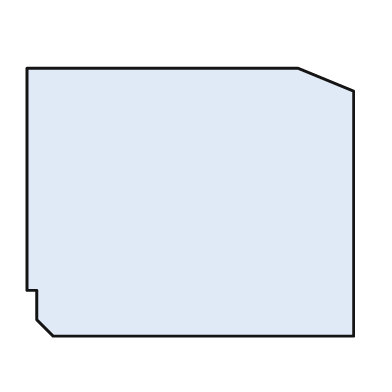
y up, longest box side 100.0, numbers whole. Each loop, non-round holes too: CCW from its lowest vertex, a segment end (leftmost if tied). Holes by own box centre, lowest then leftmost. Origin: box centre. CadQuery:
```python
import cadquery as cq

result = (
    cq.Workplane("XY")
    .moveTo(-42.0, -41.0)
    .lineTo(50.0, -41.0)
    .lineTo(50.0, 34.0)
    .lineTo(33.0, 41.0)
    .lineTo(-50.0, 41.0)
    .lineTo(-50.0, -27.0)
    .lineTo(-47.0, -27.0)
    .lineTo(-47.0, -36.0)
    .close()
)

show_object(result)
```